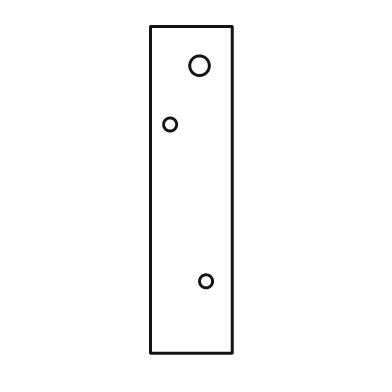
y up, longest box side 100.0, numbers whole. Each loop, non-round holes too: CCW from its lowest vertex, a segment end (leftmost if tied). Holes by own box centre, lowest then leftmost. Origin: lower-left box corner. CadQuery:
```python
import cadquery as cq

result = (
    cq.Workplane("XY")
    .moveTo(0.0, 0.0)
    .lineTo(25.0, 0.0)
    .lineTo(25.0, 100.0)
    .lineTo(0.0, 100.0)
    .close()
    .moveTo(17.0, 22.0)
    .circle(2.0)
    .moveTo(6.0, 70.0)
    .circle(2.0)
    .moveTo(15.0, 88.0)
    .circle(3.0)
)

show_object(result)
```